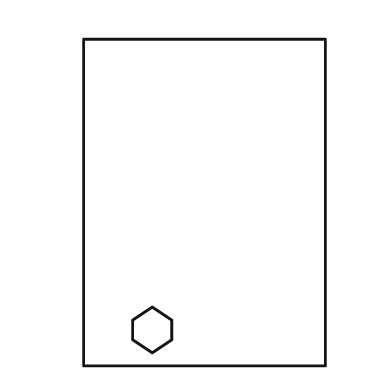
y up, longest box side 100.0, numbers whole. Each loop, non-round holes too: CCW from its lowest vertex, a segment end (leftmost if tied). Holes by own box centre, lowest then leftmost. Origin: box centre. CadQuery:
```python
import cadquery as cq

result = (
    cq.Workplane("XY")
    .moveTo(-37.0, -50.0)
    .lineTo(37.0, -50.0)
    .lineTo(37.0, 50.0)
    .lineTo(-37.0, 50.0)
    .close()
    .moveTo(-16.0, -46.0)
    .lineTo(-10.0, -42.0)
    .lineTo(-10.0, -36.0)
    .lineTo(-16.0, -32.0)
    .lineTo(-22.0, -36.0)
    .lineTo(-22.0, -42.0)
    .close()
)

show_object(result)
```